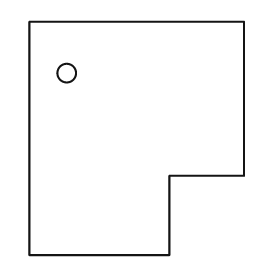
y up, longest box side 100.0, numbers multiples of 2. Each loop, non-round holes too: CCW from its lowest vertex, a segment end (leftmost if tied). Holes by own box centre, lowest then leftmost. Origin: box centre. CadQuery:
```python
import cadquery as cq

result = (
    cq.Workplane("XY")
    .moveTo(-46.0, -50.0)
    .lineTo(14.0, -50.0)
    .lineTo(14.0, -16.0)
    .lineTo(46.0, -16.0)
    .lineTo(46.0, 50.0)
    .lineTo(-46.0, 50.0)
    .close()
    .moveTo(-30.0, 28.0)
    .circle(4.0)
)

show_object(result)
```